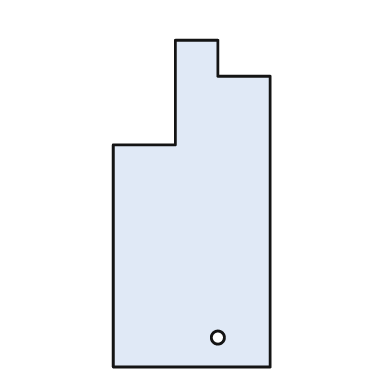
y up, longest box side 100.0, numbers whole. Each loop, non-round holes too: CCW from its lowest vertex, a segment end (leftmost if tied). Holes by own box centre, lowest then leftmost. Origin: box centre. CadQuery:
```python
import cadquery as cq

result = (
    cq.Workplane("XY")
    .moveTo(-24.0, -50.0)
    .lineTo(24.0, -50.0)
    .lineTo(24.0, 39.0)
    .lineTo(8.0, 39.0)
    .lineTo(8.0, 50.0)
    .lineTo(-5.0, 50.0)
    .lineTo(-5.0, 18.0)
    .lineTo(-24.0, 18.0)
    .close()
    .moveTo(8.0, -41.0)
    .circle(2.0)
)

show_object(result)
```